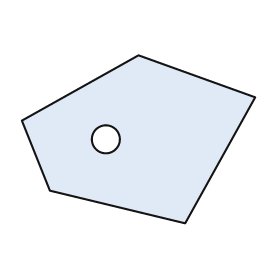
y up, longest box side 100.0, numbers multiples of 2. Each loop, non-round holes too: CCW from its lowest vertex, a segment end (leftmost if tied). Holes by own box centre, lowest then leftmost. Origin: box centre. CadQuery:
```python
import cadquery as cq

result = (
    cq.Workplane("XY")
    .moveTo(20.0, -36.0)
    .lineTo(50.0, 18.0)
    .lineTo(0.0, 36.0)
    .lineTo(-50.0, 8.0)
    .lineTo(-38.0, -22.0)
    .close()
    .moveTo(-14.0, 0.0)
    .circle(6.0)
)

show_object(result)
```